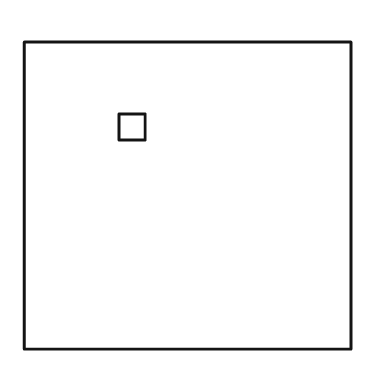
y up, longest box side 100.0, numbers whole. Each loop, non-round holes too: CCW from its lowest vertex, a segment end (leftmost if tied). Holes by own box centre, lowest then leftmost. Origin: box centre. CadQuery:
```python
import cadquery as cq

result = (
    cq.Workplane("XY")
    .moveTo(-50.0, -47.0)
    .lineTo(50.0, -47.0)
    .lineTo(50.0, 47.0)
    .lineTo(-50.0, 47.0)
    .close()
    .moveTo(-21.0, 17.0)
    .lineTo(-13.0, 17.0)
    .lineTo(-13.0, 25.0)
    .lineTo(-21.0, 25.0)
    .close()
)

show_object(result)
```